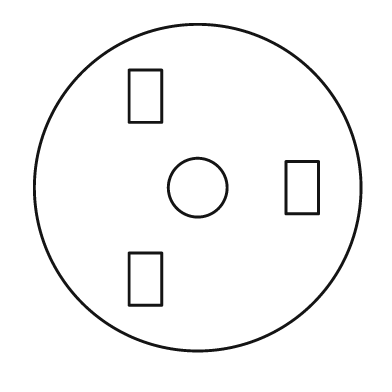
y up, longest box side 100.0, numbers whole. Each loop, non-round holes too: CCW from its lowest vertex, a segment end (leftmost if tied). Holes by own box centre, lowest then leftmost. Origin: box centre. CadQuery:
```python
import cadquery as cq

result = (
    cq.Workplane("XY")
    .moveTo(0.0, 0.0)
    .circle(50.0)
    .moveTo(-21.0, -36.0)
    .lineTo(-11.0, -36.0)
    .lineTo(-11.0, -20.0)
    .lineTo(-21.0, -20.0)
    .close()
    .moveTo(0.0, 0.0)
    .circle(9.0)
    .moveTo(27.0, -8.0)
    .lineTo(37.0, -8.0)
    .lineTo(37.0, 8.0)
    .lineTo(27.0, 8.0)
    .close()
    .moveTo(-21.0, 20.0)
    .lineTo(-11.0, 20.0)
    .lineTo(-11.0, 36.0)
    .lineTo(-21.0, 36.0)
    .close()
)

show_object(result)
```